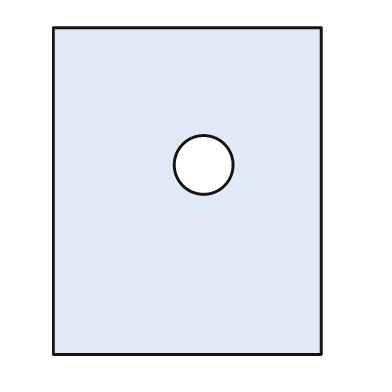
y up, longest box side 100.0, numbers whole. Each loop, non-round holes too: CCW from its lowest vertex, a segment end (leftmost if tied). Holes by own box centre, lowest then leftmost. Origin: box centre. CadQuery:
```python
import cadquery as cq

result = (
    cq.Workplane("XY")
    .moveTo(-41.0, -50.0)
    .lineTo(41.0, -50.0)
    .lineTo(41.0, 50.0)
    .lineTo(-41.0, 50.0)
    .close()
    .moveTo(5.0, 8.0)
    .circle(9.0)
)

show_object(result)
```